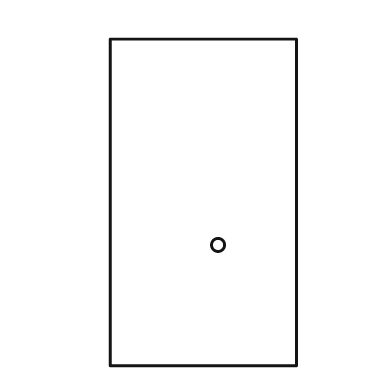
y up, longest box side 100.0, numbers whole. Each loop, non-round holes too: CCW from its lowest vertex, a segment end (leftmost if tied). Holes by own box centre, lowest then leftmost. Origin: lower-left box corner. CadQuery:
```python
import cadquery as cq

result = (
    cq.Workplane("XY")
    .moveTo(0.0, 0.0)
    .lineTo(57.0, 0.0)
    .lineTo(57.0, 100.0)
    .lineTo(0.0, 100.0)
    .close()
    .moveTo(33.0, 37.0)
    .circle(2.0)
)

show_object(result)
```